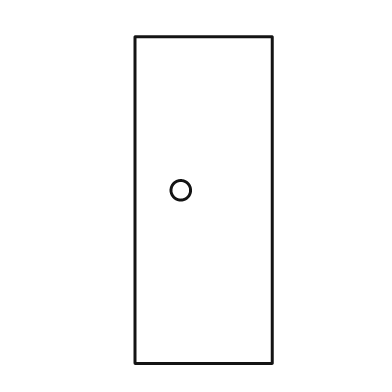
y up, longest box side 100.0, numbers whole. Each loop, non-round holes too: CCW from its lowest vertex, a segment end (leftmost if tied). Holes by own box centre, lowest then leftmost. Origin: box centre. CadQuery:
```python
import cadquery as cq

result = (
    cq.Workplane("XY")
    .moveTo(-21.0, -50.0)
    .lineTo(21.0, -50.0)
    .lineTo(21.0, 50.0)
    .lineTo(-21.0, 50.0)
    .close()
    .moveTo(-7.0, 3.0)
    .circle(3.0)
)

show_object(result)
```